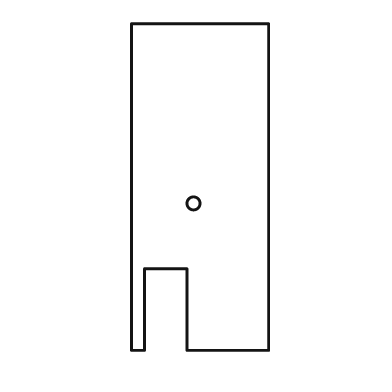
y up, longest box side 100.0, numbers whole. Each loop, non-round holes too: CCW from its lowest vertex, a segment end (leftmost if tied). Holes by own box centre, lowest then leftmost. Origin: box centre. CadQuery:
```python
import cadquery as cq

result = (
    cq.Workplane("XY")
    .moveTo(-21.0, -50.0)
    .lineTo(-17.0, -50.0)
    .lineTo(-17.0, -25.0)
    .lineTo(-4.0, -25.0)
    .lineTo(-4.0, -50.0)
    .lineTo(21.0, -50.0)
    .lineTo(21.0, 50.0)
    .lineTo(-21.0, 50.0)
    .close()
    .moveTo(-2.0, -5.0)
    .circle(2.0)
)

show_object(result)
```